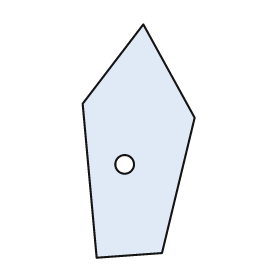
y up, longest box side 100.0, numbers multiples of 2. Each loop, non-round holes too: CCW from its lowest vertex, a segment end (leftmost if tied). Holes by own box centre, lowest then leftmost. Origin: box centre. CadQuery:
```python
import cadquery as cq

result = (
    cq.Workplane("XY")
    .moveTo(-18.0, -50.0)
    .lineTo(10.0, -48.0)
    .lineTo(24.0, 10.0)
    .lineTo(2.0, 50.0)
    .lineTo(-24.0, 16.0)
    .close()
    .moveTo(-6.0, -10.0)
    .circle(4.0)
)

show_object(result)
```